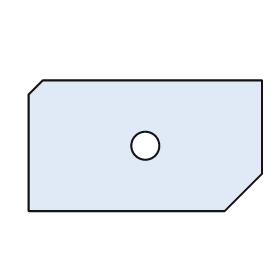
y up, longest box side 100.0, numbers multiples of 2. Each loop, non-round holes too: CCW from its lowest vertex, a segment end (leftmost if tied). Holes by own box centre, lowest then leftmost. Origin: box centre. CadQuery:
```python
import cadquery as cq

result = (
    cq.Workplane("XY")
    .moveTo(-50.0, -28.0)
    .lineTo(34.0, -28.0)
    .lineTo(50.0, -12.0)
    .lineTo(50.0, 28.0)
    .lineTo(-44.0, 28.0)
    .lineTo(-50.0, 22.0)
    .close()
    .moveTo(0.0, 0.0)
    .circle(6.0)
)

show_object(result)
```